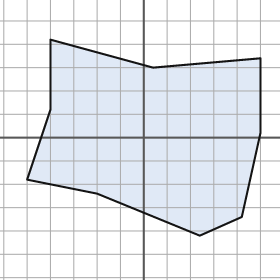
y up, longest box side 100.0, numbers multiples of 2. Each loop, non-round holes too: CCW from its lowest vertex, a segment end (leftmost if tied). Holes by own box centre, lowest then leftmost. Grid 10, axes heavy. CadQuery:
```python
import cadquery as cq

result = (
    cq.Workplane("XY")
    .moveTo(24.0, -42.0)
    .lineTo(42.0, -34.0)
    .lineTo(50.0, 2.0)
    .lineTo(50.0, 34.0)
    .lineTo(4.0, 30.0)
    .lineTo(-40.0, 42.0)
    .lineTo(-40.0, 12.0)
    .lineTo(-50.0, -18.0)
    .lineTo(-20.0, -24.0)
    .close()
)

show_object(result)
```